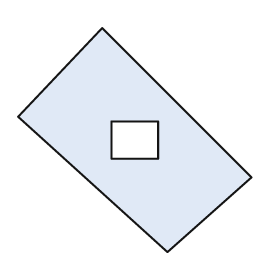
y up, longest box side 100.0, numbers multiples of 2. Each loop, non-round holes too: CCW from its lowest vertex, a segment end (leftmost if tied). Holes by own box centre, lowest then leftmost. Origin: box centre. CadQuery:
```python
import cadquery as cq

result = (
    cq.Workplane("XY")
    .moveTo(14.0, -48.0)
    .lineTo(50.0, -16.0)
    .lineTo(-14.0, 48.0)
    .lineTo(-50.0, 10.0)
    .close()
    .moveTo(-10.0, -8.0)
    .lineTo(10.0, -8.0)
    .lineTo(10.0, 8.0)
    .lineTo(-10.0, 8.0)
    .close()
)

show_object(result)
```